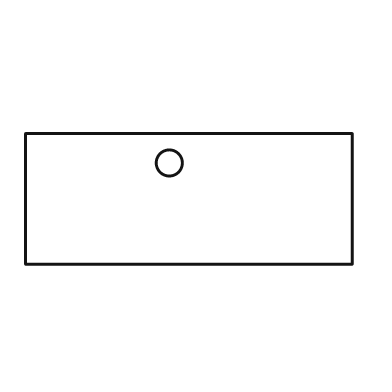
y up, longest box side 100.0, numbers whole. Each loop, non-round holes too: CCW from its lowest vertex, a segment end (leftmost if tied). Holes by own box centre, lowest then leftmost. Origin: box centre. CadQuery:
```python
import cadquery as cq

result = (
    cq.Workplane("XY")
    .moveTo(-50.0, -20.0)
    .lineTo(50.0, -20.0)
    .lineTo(50.0, 20.0)
    .lineTo(-50.0, 20.0)
    .close()
    .moveTo(-6.0, 11.0)
    .circle(4.0)
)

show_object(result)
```